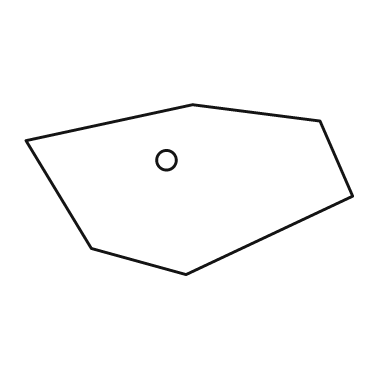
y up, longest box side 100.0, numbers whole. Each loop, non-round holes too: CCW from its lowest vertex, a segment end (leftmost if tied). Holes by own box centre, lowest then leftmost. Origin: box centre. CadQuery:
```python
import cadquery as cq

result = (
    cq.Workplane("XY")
    .moveTo(-1.0, -26.0)
    .lineTo(50.0, -2.0)
    .lineTo(40.0, 21.0)
    .lineTo(1.0, 26.0)
    .lineTo(-50.0, 15.0)
    .lineTo(-30.0, -18.0)
    .close()
    .moveTo(-7.0, 9.0)
    .circle(3.0)
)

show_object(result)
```